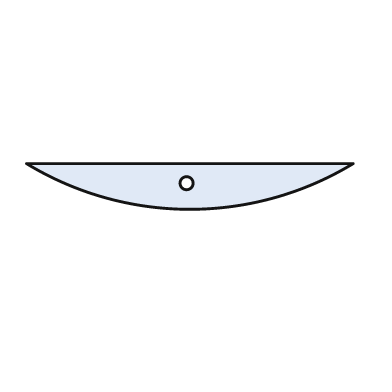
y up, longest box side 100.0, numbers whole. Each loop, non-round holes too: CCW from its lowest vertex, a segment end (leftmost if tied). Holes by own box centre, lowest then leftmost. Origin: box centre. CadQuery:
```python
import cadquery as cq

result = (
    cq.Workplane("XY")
    .moveTo(-50.0, 7.0)
    .threePointArc((0.0, -7.0), (50.0, 7.0))
    .close()
    .moveTo(-1.0, 1.0)
    .circle(2.0)
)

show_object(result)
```